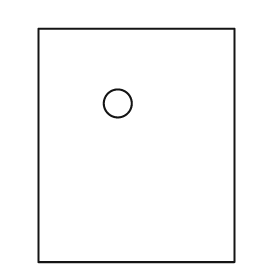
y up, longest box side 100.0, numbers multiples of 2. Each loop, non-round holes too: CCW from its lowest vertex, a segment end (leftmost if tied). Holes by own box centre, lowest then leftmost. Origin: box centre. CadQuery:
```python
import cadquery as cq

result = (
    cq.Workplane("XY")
    .moveTo(-42.0, -50.0)
    .lineTo(42.0, -50.0)
    .lineTo(42.0, 50.0)
    .lineTo(-42.0, 50.0)
    .close()
    .moveTo(-8.0, 18.0)
    .circle(6.0)
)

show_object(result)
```